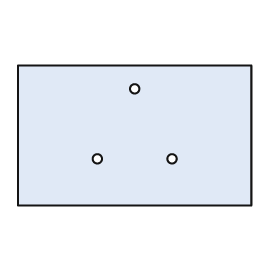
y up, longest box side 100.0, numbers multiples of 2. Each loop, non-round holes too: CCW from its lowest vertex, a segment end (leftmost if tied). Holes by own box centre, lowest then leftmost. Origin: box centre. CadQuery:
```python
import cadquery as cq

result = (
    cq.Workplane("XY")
    .moveTo(-50.0, -30.0)
    .lineTo(50.0, -30.0)
    .lineTo(50.0, 30.0)
    .lineTo(-50.0, 30.0)
    .close()
    .moveTo(-16.0, -10.0)
    .circle(2.0)
    .moveTo(16.0, -10.0)
    .circle(2.0)
    .moveTo(0.0, 20.0)
    .circle(2.0)
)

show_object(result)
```